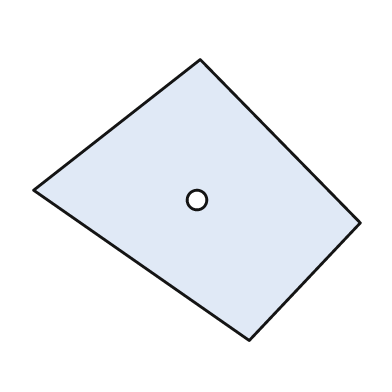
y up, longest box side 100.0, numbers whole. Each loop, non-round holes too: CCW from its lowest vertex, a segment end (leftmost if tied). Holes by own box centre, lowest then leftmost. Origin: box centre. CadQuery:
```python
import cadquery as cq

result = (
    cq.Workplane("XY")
    .moveTo(16.0, -43.0)
    .lineTo(50.0, -7.0)
    .lineTo(1.0, 43.0)
    .lineTo(-50.0, 3.0)
    .close()
    .moveTo(0.0, 0.0)
    .circle(3.0)
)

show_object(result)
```